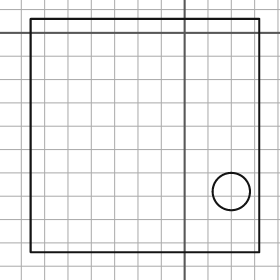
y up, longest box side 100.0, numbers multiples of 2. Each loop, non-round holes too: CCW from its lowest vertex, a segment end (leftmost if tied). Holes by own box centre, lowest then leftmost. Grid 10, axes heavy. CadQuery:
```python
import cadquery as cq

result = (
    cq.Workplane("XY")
    .moveTo(-66.0, -94.0)
    .lineTo(32.0, -94.0)
    .lineTo(32.0, 6.0)
    .lineTo(-66.0, 6.0)
    .close()
    .moveTo(20.0, -68.0)
    .circle(8.0)
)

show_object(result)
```